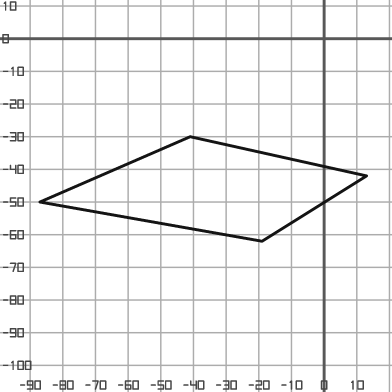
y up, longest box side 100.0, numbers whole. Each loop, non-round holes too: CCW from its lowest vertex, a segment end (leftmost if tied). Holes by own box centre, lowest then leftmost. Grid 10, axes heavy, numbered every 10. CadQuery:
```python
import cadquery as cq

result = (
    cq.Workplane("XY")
    .moveTo(-19.0, -62.0)
    .lineTo(13.0, -42.0)
    .lineTo(-41.0, -30.0)
    .lineTo(-87.0, -50.0)
    .close()
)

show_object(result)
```